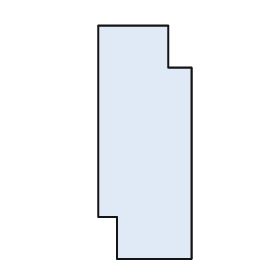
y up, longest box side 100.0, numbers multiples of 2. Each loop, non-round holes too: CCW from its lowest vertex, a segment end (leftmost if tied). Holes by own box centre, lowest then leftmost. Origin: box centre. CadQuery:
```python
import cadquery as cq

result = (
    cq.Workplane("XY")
    .moveTo(-12.0, -50.0)
    .lineTo(20.0, -50.0)
    .lineTo(20.0, 32.0)
    .lineTo(10.0, 32.0)
    .lineTo(10.0, 50.0)
    .lineTo(-20.0, 50.0)
    .lineTo(-20.0, -32.0)
    .lineTo(-12.0, -32.0)
    .close()
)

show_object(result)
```